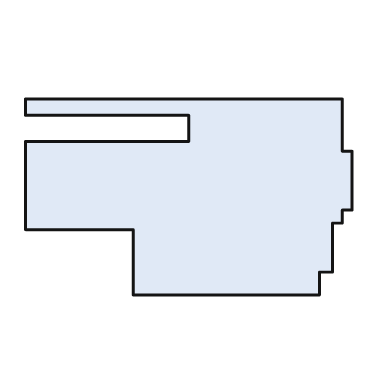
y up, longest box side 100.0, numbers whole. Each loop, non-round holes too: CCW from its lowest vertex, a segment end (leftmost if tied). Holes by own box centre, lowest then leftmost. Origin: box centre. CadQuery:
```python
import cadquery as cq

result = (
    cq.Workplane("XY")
    .moveTo(-17.0, -30.0)
    .lineTo(40.0, -30.0)
    .lineTo(40.0, -23.0)
    .lineTo(44.0, -23.0)
    .lineTo(44.0, -8.0)
    .lineTo(47.0, -8.0)
    .lineTo(47.0, -4.0)
    .lineTo(50.0, -4.0)
    .lineTo(50.0, 14.0)
    .lineTo(47.0, 14.0)
    .lineTo(47.0, 30.0)
    .lineTo(-50.0, 30.0)
    .lineTo(-50.0, 25.0)
    .lineTo(0.0, 25.0)
    .lineTo(0.0, 17.0)
    .lineTo(-50.0, 17.0)
    .lineTo(-50.0, -10.0)
    .lineTo(-17.0, -10.0)
    .close()
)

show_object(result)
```